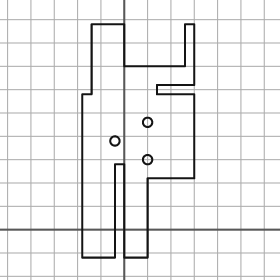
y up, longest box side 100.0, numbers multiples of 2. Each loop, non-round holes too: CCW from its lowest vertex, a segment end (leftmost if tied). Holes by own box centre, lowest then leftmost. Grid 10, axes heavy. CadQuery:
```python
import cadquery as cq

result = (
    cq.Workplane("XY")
    .moveTo(-18.0, -12.0)
    .lineTo(-4.0, -12.0)
    .lineTo(-4.0, 28.0)
    .lineTo(0.0, 28.0)
    .lineTo(0.0, -12.0)
    .lineTo(10.0, -12.0)
    .lineTo(10.0, 22.0)
    .lineTo(30.0, 22.0)
    .lineTo(30.0, 58.0)
    .lineTo(14.0, 58.0)
    .lineTo(14.0, 62.0)
    .lineTo(30.0, 62.0)
    .lineTo(30.0, 88.0)
    .lineTo(26.0, 88.0)
    .lineTo(26.0, 70.0)
    .lineTo(0.0, 70.0)
    .lineTo(0.0, 88.0)
    .lineTo(-14.0, 88.0)
    .lineTo(-14.0, 58.0)
    .lineTo(-18.0, 58.0)
    .close()
    .moveTo(10.0, 30.0)
    .circle(2.0)
    .moveTo(-4.0, 38.0)
    .circle(2.0)
    .moveTo(10.0, 46.0)
    .circle(2.0)
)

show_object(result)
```